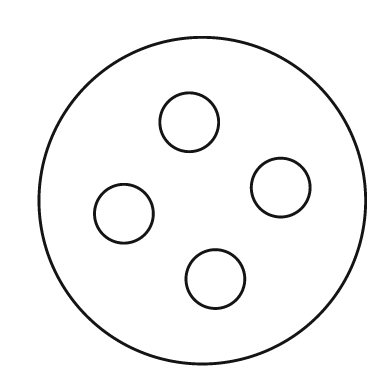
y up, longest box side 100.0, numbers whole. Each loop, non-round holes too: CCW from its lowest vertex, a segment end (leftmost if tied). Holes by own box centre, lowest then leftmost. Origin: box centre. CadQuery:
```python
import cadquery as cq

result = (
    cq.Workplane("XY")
    .moveTo(0.0, 0.0)
    .circle(50.0)
    .moveTo(4.0, -24.0)
    .circle(9.0)
    .moveTo(-24.0, -4.0)
    .circle(9.0)
    .moveTo(24.0, 4.0)
    .circle(9.0)
    .moveTo(-4.0, 24.0)
    .circle(9.0)
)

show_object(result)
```